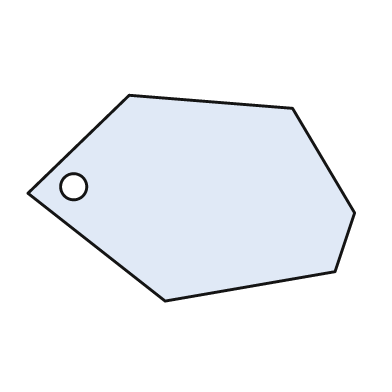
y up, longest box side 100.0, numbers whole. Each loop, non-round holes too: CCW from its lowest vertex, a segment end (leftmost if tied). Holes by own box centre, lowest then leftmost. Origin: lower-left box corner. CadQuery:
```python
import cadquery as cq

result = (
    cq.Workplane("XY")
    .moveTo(42.0, 0.0)
    .lineTo(94.0, 9.0)
    .lineTo(100.0, 27.0)
    .lineTo(81.0, 59.0)
    .lineTo(31.0, 63.0)
    .lineTo(0.0, 33.0)
    .close()
    .moveTo(14.0, 35.0)
    .circle(4.0)
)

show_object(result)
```